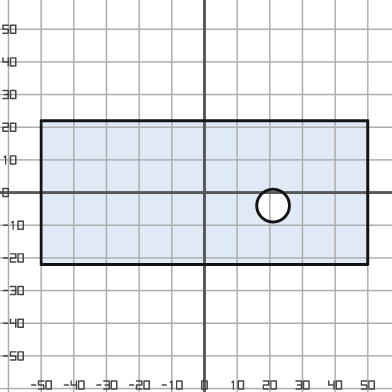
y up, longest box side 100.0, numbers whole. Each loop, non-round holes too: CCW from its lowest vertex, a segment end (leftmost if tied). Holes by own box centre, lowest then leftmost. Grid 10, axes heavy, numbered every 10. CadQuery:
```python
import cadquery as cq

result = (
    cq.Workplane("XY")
    .moveTo(-50.0, -22.0)
    .lineTo(50.0, -22.0)
    .lineTo(50.0, 22.0)
    .lineTo(-50.0, 22.0)
    .close()
    .moveTo(21.0, -4.0)
    .circle(5.0)
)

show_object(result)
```